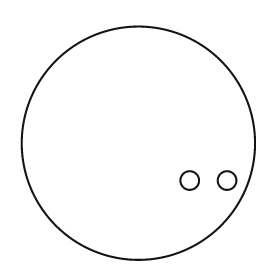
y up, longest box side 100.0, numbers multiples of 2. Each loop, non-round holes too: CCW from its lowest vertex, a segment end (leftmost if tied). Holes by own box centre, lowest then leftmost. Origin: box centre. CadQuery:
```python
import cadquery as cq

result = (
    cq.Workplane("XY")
    .moveTo(0.0, 0.0)
    .circle(50.0)
    .moveTo(22.0, -16.0)
    .circle(4.0)
    .moveTo(38.0, -16.0)
    .circle(4.0)
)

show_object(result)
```